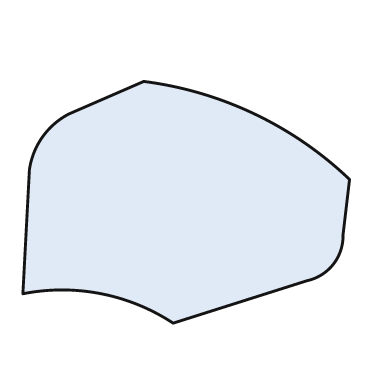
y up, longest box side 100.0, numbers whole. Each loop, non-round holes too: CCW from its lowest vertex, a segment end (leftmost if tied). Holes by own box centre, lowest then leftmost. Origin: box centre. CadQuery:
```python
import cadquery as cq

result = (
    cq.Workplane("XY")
    .moveTo(-4.0, -37.0)
    .lineTo(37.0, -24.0)
    .threePointArc((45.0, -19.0), (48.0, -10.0))
    .lineTo(50.0, 7.0)
    .threePointArc((21.0, 27.0), (-13.0, 37.0))
    .lineTo(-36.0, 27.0)
    .threePointArc((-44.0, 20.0), (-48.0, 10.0))
    .lineTo(-50.0, -28.0)
    .threePointArc((-26.0, -28.0), (-4.0, -37.0))
    .close()
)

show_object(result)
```